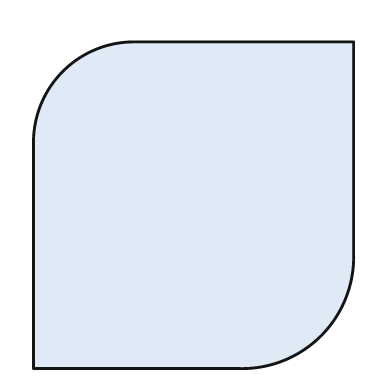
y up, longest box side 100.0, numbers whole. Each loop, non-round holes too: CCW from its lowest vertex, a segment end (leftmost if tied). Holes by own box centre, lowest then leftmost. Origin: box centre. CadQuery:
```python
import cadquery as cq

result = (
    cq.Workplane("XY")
    .moveTo(-49.0, -50.0)
    .lineTo(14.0, -50.0)
    .threePointArc((39.0, -40.0), (49.0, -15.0))
    .lineTo(49.0, 50.0)
    .lineTo(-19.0, 50.0)
    .threePointArc((-40.0, 41.0), (-49.0, 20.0))
    .close()
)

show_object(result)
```